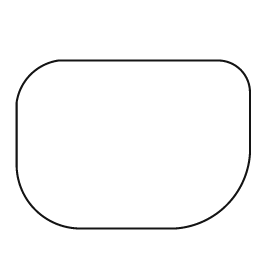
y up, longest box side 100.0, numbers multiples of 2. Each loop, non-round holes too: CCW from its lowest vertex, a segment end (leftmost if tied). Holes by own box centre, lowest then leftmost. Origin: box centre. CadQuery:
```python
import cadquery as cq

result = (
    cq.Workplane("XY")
    .moveTo(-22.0, -36.0)
    .lineTo(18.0, -36.0)
    .threePointArc((40.0, -26.0), (50.0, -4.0))
    .lineTo(50.0, 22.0)
    .threePointArc((46.0, 32.0), (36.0, 36.0))
    .lineTo(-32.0, 36.0)
    .threePointArc((-44.0, 30.0), (-50.0, 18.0))
    .lineTo(-50.0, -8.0)
    .threePointArc((-42.0, -28.0), (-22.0, -36.0))
    .close()
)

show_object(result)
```